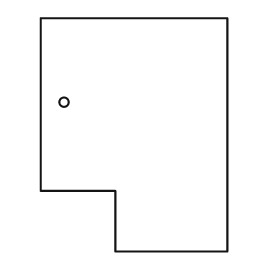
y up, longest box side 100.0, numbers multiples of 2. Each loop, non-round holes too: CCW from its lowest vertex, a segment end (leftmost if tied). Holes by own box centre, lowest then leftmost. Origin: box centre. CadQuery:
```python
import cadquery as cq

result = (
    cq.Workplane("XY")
    .moveTo(-8.0, -50.0)
    .lineTo(40.0, -50.0)
    .lineTo(40.0, 50.0)
    .lineTo(-40.0, 50.0)
    .lineTo(-40.0, -24.0)
    .lineTo(-8.0, -24.0)
    .close()
    .moveTo(-30.0, 14.0)
    .circle(2.0)
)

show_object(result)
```